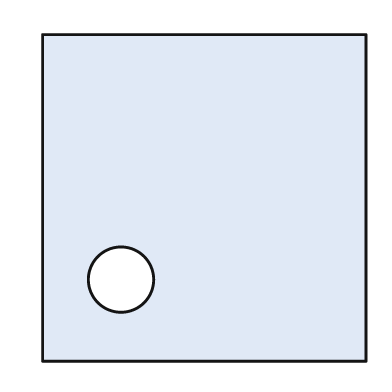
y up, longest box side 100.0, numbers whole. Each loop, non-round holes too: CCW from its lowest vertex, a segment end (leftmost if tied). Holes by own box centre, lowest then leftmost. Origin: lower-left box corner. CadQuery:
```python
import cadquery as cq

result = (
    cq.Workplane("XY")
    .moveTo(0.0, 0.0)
    .lineTo(99.0, 0.0)
    .lineTo(99.0, 100.0)
    .lineTo(0.0, 100.0)
    .close()
    .moveTo(24.0, 25.0)
    .circle(10.0)
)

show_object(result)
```